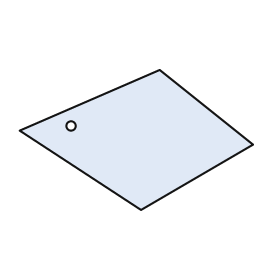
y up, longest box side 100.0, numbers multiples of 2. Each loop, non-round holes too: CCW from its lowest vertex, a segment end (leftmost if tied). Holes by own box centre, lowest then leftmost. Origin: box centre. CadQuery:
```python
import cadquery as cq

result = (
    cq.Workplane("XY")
    .moveTo(2.0, -30.0)
    .lineTo(50.0, -2.0)
    .lineTo(10.0, 30.0)
    .lineTo(-50.0, 4.0)
    .close()
    .moveTo(-28.0, 6.0)
    .circle(2.0)
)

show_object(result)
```